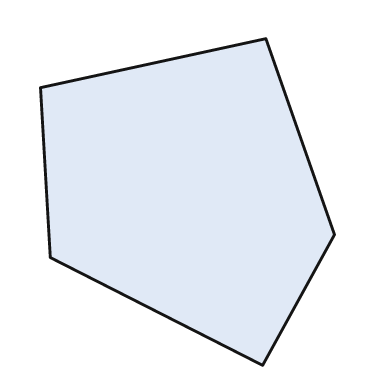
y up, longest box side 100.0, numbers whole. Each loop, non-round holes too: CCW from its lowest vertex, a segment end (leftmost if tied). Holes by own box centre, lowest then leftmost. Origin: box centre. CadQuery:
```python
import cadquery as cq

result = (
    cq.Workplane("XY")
    .moveTo(23.0, -50.0)
    .lineTo(45.0, -10.0)
    .lineTo(24.0, 50.0)
    .lineTo(-45.0, 35.0)
    .lineTo(-42.0, -17.0)
    .close()
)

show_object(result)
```